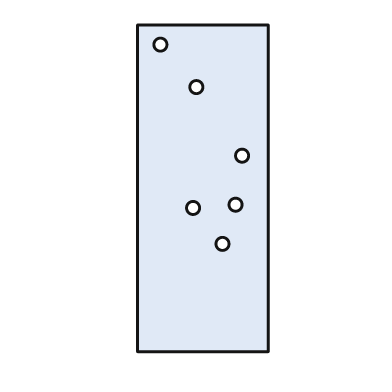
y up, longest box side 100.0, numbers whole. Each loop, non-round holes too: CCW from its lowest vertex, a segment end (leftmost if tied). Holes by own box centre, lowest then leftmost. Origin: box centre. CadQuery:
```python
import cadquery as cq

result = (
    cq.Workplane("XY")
    .moveTo(-20.0, -50.0)
    .lineTo(20.0, -50.0)
    .lineTo(20.0, 50.0)
    .lineTo(-20.0, 50.0)
    .close()
    .moveTo(6.0, -17.0)
    .circle(2.0)
    .moveTo(-3.0, -6.0)
    .circle(2.0)
    .moveTo(10.0, -5.0)
    .circle(2.0)
    .moveTo(12.0, 10.0)
    .circle(2.0)
    .moveTo(-2.0, 31.0)
    .circle(2.0)
    .moveTo(-13.0, 44.0)
    .circle(2.0)
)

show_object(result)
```